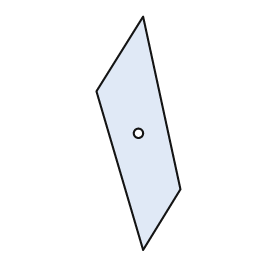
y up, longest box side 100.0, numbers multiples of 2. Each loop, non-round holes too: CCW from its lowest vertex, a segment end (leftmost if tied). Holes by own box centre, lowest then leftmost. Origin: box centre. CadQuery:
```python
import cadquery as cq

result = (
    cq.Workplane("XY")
    .moveTo(2.0, -50.0)
    .lineTo(18.0, -24.0)
    .lineTo(2.0, 50.0)
    .lineTo(-18.0, 18.0)
    .close()
    .moveTo(0.0, 0.0)
    .circle(2.0)
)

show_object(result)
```